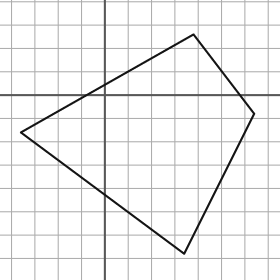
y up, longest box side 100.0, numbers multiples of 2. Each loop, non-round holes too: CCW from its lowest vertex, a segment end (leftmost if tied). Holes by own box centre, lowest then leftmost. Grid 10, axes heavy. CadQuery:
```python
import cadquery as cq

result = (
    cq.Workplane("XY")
    .moveTo(34.0, -68.0)
    .lineTo(64.0, -8.0)
    .lineTo(38.0, 26.0)
    .lineTo(-36.0, -16.0)
    .close()
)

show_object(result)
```